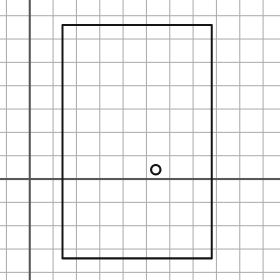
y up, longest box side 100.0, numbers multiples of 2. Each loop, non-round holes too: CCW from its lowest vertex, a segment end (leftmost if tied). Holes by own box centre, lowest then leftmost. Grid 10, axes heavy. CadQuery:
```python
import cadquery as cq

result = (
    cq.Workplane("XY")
    .moveTo(14.0, -34.0)
    .lineTo(78.0, -34.0)
    .lineTo(78.0, 66.0)
    .lineTo(14.0, 66.0)
    .close()
    .moveTo(54.0, 4.0)
    .circle(2.0)
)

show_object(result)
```